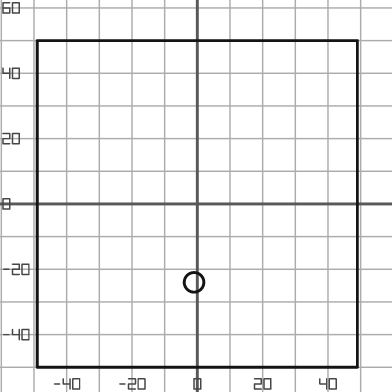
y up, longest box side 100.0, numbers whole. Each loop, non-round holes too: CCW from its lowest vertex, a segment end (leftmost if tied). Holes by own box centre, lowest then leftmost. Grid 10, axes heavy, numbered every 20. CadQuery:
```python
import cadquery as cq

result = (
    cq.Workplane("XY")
    .moveTo(-49.0, -50.0)
    .lineTo(49.0, -50.0)
    .lineTo(49.0, 50.0)
    .lineTo(-49.0, 50.0)
    .close()
    .moveTo(-1.0, -24.0)
    .circle(3.0)
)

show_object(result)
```